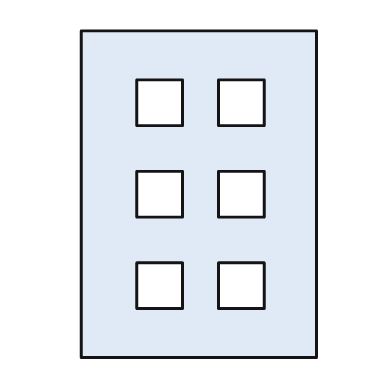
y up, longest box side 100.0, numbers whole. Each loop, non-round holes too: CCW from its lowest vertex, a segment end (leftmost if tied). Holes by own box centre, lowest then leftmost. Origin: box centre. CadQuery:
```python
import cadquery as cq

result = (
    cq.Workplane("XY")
    .moveTo(-36.0, -50.0)
    .lineTo(36.0, -50.0)
    .lineTo(36.0, 50.0)
    .lineTo(-36.0, 50.0)
    .close()
    .moveTo(-19.0, -35.0)
    .lineTo(-5.0, -35.0)
    .lineTo(-5.0, -21.0)
    .lineTo(-19.0, -21.0)
    .close()
    .moveTo(6.0, -35.0)
    .lineTo(20.0, -35.0)
    .lineTo(20.0, -21.0)
    .lineTo(6.0, -21.0)
    .close()
    .moveTo(-19.0, -7.0)
    .lineTo(-5.0, -7.0)
    .lineTo(-5.0, 7.0)
    .lineTo(-19.0, 7.0)
    .close()
    .moveTo(6.0, -7.0)
    .lineTo(20.0, -7.0)
    .lineTo(20.0, 7.0)
    .lineTo(6.0, 7.0)
    .close()
    .moveTo(-19.0, 21.0)
    .lineTo(-5.0, 21.0)
    .lineTo(-5.0, 35.0)
    .lineTo(-19.0, 35.0)
    .close()
    .moveTo(6.0, 21.0)
    .lineTo(20.0, 21.0)
    .lineTo(20.0, 35.0)
    .lineTo(6.0, 35.0)
    .close()
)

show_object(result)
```